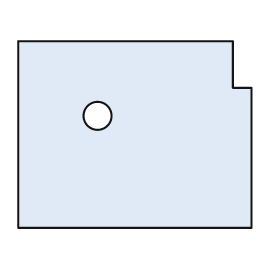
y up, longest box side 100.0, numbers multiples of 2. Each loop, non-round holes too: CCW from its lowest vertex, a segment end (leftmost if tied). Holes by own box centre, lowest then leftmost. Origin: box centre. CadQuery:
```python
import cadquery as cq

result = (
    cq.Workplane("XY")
    .moveTo(-50.0, -40.0)
    .lineTo(50.0, -40.0)
    .lineTo(50.0, 20.0)
    .lineTo(42.0, 20.0)
    .lineTo(42.0, 40.0)
    .lineTo(-50.0, 40.0)
    .close()
    .moveTo(-16.0, 8.0)
    .circle(6.0)
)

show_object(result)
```